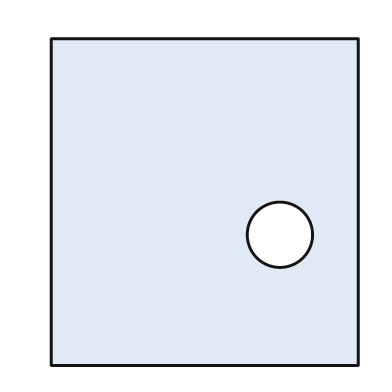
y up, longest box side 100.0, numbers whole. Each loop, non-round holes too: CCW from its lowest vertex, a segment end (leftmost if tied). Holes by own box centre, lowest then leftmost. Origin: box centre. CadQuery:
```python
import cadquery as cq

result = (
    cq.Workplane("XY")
    .moveTo(-47.0, -50.0)
    .lineTo(47.0, -50.0)
    .lineTo(47.0, 50.0)
    .lineTo(-47.0, 50.0)
    .close()
    .moveTo(23.0, -10.0)
    .circle(10.0)
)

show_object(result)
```